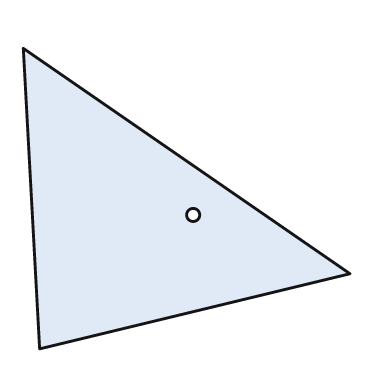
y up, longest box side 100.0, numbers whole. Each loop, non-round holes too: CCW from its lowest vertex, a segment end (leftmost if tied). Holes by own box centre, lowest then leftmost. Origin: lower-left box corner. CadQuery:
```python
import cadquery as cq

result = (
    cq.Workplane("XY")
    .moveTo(5.0, 0.0)
    .lineTo(100.0, 23.0)
    .lineTo(0.0, 92.0)
    .close()
    .moveTo(52.0, 41.0)
    .circle(2.0)
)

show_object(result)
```